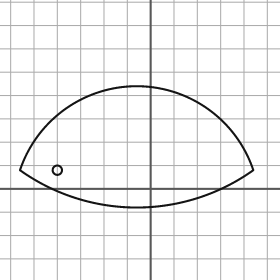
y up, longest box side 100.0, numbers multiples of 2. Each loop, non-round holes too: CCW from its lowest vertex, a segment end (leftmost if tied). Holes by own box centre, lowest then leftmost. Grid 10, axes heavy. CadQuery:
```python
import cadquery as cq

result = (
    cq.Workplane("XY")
    .moveTo(-56.0, 8.0)
    .threePointArc((-6.0, -8.0), (44.0, 8.0))
    .threePointArc((-6.0, 44.0), (-56.0, 8.0))
    .close()
    .moveTo(-40.0, 8.0)
    .circle(2.0)
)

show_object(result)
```